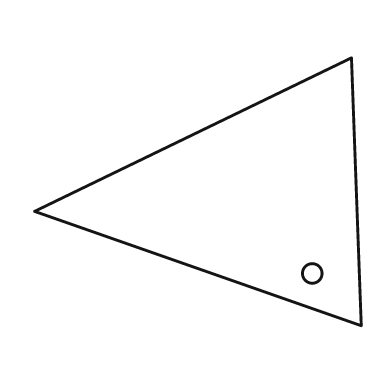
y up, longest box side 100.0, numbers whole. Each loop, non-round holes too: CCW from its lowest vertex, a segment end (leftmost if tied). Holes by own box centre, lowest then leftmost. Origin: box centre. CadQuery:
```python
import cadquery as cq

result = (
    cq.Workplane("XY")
    .moveTo(50.0, -41.0)
    .lineTo(47.0, 41.0)
    .lineTo(-50.0, -6.0)
    .close()
    .moveTo(35.0, -25.0)
    .circle(3.0)
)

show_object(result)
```